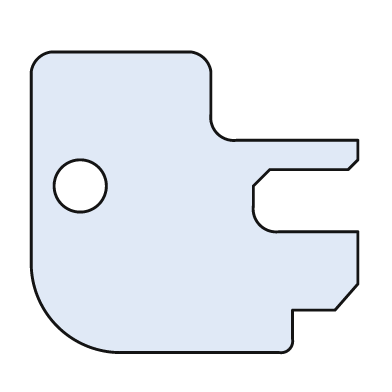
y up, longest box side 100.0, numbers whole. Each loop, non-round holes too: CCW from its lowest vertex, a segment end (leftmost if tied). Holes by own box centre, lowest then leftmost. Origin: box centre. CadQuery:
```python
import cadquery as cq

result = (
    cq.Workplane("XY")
    .moveTo(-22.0, -46.0)
    .lineTo(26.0, -46.0)
    .threePointArc((29.0, -45.0), (30.0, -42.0))
    .lineTo(30.0, -33.0)
    .lineTo(43.0, -33.0)
    .lineTo(50.0, -25.0)
    .lineTo(50.0, -9.0)
    .lineTo(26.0, -9.0)
    .threePointArc((20.0, -7.0), (18.0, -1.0))
    .lineTo(18.0, 5.0)
    .lineTo(23.0, 10.0)
    .lineTo(47.0, 10.0)
    .lineTo(50.0, 13.0)
    .lineTo(50.0, 19.0)
    .lineTo(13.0, 19.0)
    .threePointArc((7.0, 21.0), (5.0, 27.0))
    .lineTo(5.0, 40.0)
    .threePointArc((3.0, 44.0), (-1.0, 46.0))
    .lineTo(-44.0, 46.0)
    .threePointArc((-48.0, 44.0), (-50.0, 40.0))
    .lineTo(-50.0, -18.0)
    .threePointArc((-42.0, -38.0), (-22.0, -46.0))
    .close()
    .moveTo(-35.0, 5.0)
    .circle(8.0)
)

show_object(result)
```